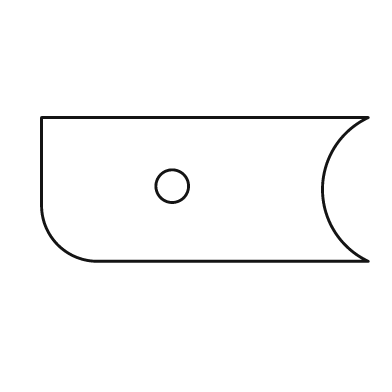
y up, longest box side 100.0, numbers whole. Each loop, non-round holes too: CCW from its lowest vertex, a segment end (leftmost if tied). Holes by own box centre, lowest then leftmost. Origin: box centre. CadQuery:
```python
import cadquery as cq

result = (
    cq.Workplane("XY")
    .moveTo(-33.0, -22.0)
    .lineTo(50.0, -22.0)
    .threePointArc((36.0, 0.0), (50.0, 22.0))
    .lineTo(-50.0, 22.0)
    .lineTo(-50.0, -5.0)
    .threePointArc((-45.0, -17.0), (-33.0, -22.0))
    .close()
    .moveTo(-10.0, 1.0)
    .circle(5.0)
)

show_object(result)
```